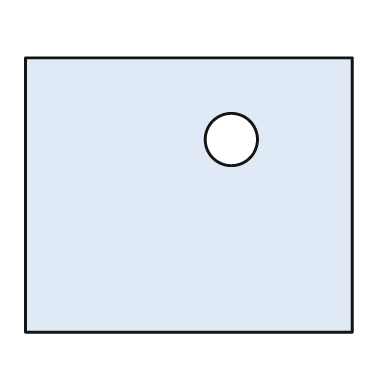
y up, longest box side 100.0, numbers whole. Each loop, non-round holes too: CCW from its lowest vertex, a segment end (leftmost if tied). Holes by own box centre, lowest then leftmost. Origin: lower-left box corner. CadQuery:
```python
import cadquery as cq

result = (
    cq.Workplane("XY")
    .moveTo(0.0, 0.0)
    .lineTo(100.0, 0.0)
    .lineTo(100.0, 84.0)
    .lineTo(0.0, 84.0)
    .close()
    .moveTo(63.0, 59.0)
    .circle(8.0)
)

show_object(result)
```